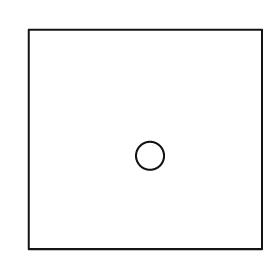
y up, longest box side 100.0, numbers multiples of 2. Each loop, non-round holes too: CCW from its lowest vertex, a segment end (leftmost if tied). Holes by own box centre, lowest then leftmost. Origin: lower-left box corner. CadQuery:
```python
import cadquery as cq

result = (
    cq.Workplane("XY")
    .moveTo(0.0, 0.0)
    .lineTo(100.0, 0.0)
    .lineTo(100.0, 94.0)
    .lineTo(0.0, 94.0)
    .close()
    .moveTo(52.0, 40.0)
    .circle(6.0)
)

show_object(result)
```